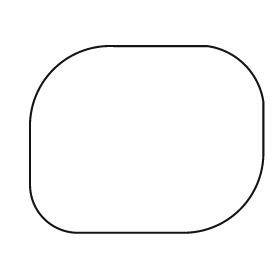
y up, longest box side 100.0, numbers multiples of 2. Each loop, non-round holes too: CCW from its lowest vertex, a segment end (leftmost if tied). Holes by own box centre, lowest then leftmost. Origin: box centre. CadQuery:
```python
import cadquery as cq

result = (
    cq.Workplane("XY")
    .moveTo(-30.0, -40.0)
    .lineTo(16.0, -40.0)
    .threePointArc((40.0, -30.0), (50.0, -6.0))
    .lineTo(50.0, 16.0)
    .threePointArc((42.0, 32.0), (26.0, 40.0))
    .lineTo(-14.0, 40.0)
    .threePointArc((-40.0, 30.0), (-50.0, 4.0))
    .lineTo(-50.0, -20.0)
    .threePointArc((-44.0, -34.0), (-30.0, -40.0))
    .close()
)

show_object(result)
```